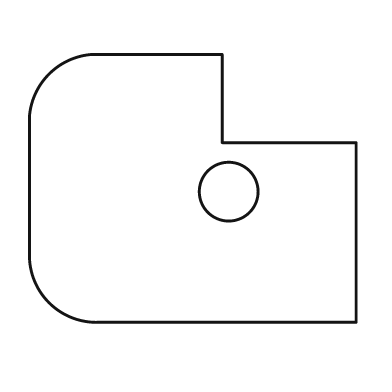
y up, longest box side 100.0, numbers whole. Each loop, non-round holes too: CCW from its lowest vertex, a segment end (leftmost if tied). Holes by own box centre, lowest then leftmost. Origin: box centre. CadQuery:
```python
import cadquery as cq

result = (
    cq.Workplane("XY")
    .moveTo(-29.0, -41.0)
    .lineTo(50.0, -41.0)
    .lineTo(50.0, 14.0)
    .lineTo(9.0, 14.0)
    .lineTo(9.0, 41.0)
    .lineTo(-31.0, 41.0)
    .threePointArc((-44.0, 35.0), (-50.0, 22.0))
    .lineTo(-50.0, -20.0)
    .threePointArc((-44.0, -35.0), (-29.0, -41.0))
    .close()
    .moveTo(11.0, -1.0)
    .circle(9.0)
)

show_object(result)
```